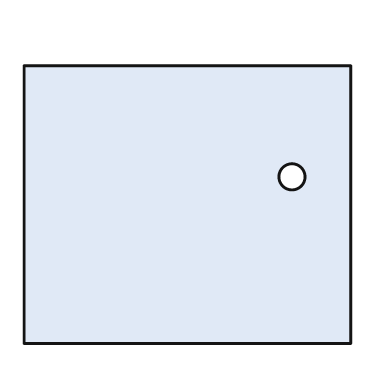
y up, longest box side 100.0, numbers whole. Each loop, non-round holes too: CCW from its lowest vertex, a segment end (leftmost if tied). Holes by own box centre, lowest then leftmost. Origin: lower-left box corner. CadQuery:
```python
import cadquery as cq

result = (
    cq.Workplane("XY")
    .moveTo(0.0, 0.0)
    .lineTo(100.0, 0.0)
    .lineTo(100.0, 85.0)
    .lineTo(0.0, 85.0)
    .close()
    .moveTo(82.0, 51.0)
    .circle(4.0)
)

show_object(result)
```